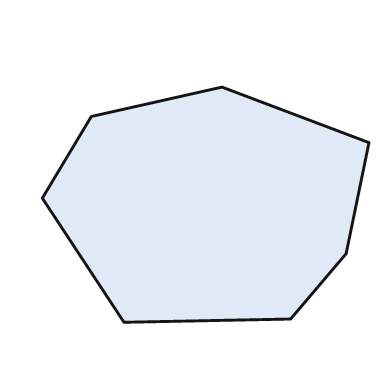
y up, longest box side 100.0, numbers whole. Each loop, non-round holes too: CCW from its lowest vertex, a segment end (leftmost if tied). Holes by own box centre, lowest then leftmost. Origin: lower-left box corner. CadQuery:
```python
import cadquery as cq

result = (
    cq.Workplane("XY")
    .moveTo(25.0, 0.0)
    .lineTo(76.0, 1.0)
    .lineTo(93.0, 21.0)
    .lineTo(100.0, 55.0)
    .lineTo(55.0, 72.0)
    .lineTo(15.0, 63.0)
    .lineTo(0.0, 38.0)
    .close()
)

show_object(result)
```